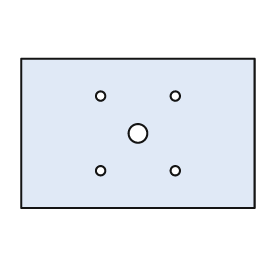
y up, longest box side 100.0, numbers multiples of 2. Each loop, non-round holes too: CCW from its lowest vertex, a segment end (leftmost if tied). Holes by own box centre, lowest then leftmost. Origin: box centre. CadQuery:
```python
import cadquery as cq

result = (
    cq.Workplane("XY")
    .moveTo(-50.0, -32.0)
    .lineTo(50.0, -32.0)
    .lineTo(50.0, 32.0)
    .lineTo(-50.0, 32.0)
    .close()
    .moveTo(-16.0, -16.0)
    .circle(2.0)
    .moveTo(16.0, -16.0)
    .circle(2.0)
    .moveTo(0.0, 0.0)
    .circle(4.0)
    .moveTo(-16.0, 16.0)
    .circle(2.0)
    .moveTo(16.0, 16.0)
    .circle(2.0)
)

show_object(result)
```